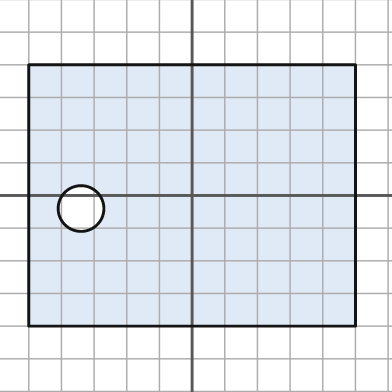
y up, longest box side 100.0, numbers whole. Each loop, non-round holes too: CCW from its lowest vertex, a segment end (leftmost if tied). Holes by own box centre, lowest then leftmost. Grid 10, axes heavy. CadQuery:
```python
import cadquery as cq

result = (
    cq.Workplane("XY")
    .moveTo(-50.0, -40.0)
    .lineTo(50.0, -40.0)
    .lineTo(50.0, 40.0)
    .lineTo(-50.0, 40.0)
    .close()
    .moveTo(-34.0, -4.0)
    .circle(7.0)
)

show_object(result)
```